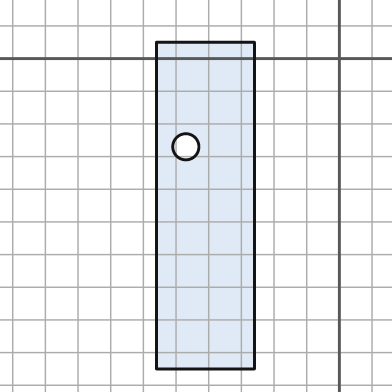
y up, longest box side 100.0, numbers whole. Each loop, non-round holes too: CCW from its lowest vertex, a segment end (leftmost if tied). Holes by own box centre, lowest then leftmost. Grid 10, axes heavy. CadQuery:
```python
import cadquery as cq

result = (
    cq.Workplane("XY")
    .moveTo(-56.0, -95.0)
    .lineTo(-26.0, -95.0)
    .lineTo(-26.0, 5.0)
    .lineTo(-56.0, 5.0)
    .close()
    .moveTo(-47.0, -27.0)
    .circle(4.0)
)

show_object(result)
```